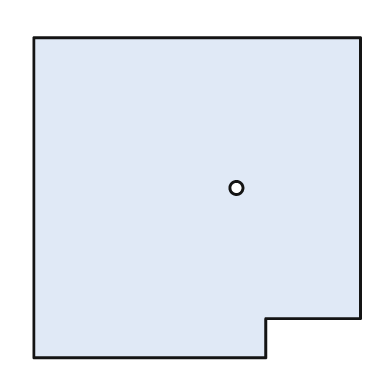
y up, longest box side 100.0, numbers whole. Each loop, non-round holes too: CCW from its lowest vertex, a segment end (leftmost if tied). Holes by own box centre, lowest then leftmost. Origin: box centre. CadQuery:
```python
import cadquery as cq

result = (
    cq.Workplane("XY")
    .moveTo(-50.0, -49.0)
    .lineTo(21.0, -49.0)
    .lineTo(21.0, -37.0)
    .lineTo(50.0, -37.0)
    .lineTo(50.0, 49.0)
    .lineTo(-50.0, 49.0)
    .close()
    .moveTo(12.0, 3.0)
    .circle(2.0)
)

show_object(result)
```